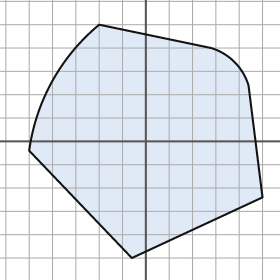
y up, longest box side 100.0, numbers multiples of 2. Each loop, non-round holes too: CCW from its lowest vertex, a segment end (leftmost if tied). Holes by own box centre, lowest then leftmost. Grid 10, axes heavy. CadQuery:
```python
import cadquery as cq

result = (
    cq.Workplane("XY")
    .moveTo(-6.0, -50.0)
    .lineTo(50.0, -24.0)
    .lineTo(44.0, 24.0)
    .threePointArc((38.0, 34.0), (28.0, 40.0))
    .lineTo(-20.0, 50.0)
    .threePointArc((-40.0, 26.0), (-50.0, -4.0))
    .close()
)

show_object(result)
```